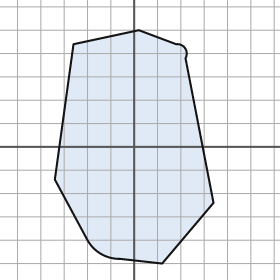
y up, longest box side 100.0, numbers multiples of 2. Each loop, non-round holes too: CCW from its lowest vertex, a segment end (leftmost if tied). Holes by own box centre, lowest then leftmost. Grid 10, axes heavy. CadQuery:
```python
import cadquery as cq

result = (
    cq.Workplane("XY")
    .moveTo(12.0, -50.0)
    .lineTo(34.0, -24.0)
    .lineTo(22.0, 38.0)
    .threePointArc((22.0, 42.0), (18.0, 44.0))
    .lineTo(2.0, 50.0)
    .lineTo(-26.0, 44.0)
    .lineTo(-34.0, -14.0)
    .lineTo(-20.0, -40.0)
    .threePointArc((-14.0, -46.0), (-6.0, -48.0))
    .close()
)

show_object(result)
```